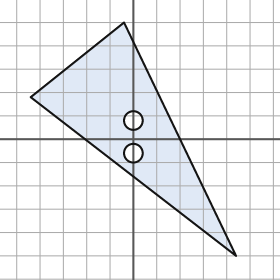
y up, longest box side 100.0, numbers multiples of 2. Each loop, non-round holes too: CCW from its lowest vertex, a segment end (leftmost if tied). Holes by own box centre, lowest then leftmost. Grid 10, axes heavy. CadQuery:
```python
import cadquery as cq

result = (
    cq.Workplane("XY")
    .moveTo(44.0, -50.0)
    .lineTo(-4.0, 50.0)
    .lineTo(-44.0, 18.0)
    .close()
    .moveTo(0.0, -6.0)
    .circle(4.0)
    .moveTo(0.0, 8.0)
    .circle(4.0)
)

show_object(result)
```